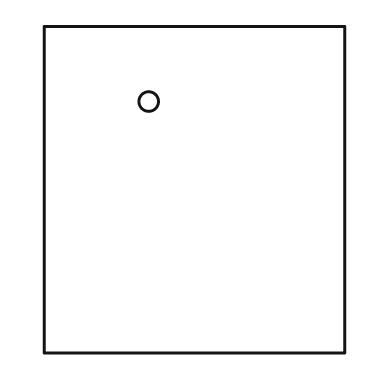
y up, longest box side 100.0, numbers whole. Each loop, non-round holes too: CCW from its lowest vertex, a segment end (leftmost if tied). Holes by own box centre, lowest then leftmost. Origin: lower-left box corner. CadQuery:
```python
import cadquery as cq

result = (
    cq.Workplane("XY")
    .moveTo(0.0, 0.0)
    .lineTo(92.0, 0.0)
    .lineTo(92.0, 100.0)
    .lineTo(0.0, 100.0)
    .close()
    .moveTo(32.0, 77.0)
    .circle(3.0)
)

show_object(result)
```